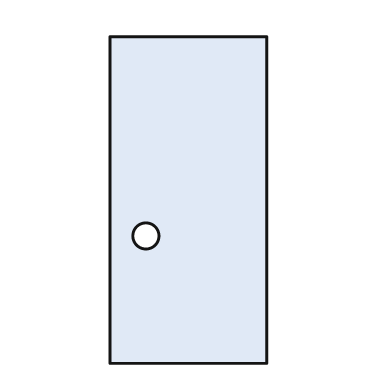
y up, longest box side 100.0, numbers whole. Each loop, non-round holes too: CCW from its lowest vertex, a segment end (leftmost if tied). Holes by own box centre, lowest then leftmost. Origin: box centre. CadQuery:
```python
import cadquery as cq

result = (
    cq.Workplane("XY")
    .moveTo(-24.0, -50.0)
    .lineTo(24.0, -50.0)
    .lineTo(24.0, 50.0)
    .lineTo(-24.0, 50.0)
    .close()
    .moveTo(-13.0, -11.0)
    .circle(4.0)
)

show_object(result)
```